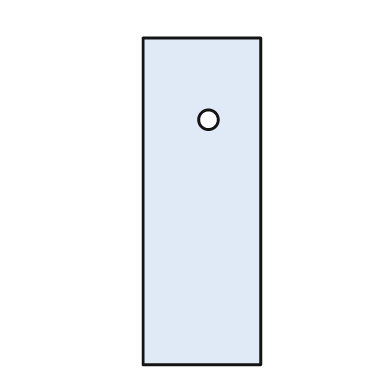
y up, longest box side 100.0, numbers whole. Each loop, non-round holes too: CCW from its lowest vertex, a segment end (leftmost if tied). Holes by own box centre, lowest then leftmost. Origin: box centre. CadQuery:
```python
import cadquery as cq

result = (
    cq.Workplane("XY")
    .moveTo(-18.0, -50.0)
    .lineTo(18.0, -50.0)
    .lineTo(18.0, 50.0)
    .lineTo(-18.0, 50.0)
    .close()
    .moveTo(2.0, 25.0)
    .circle(3.0)
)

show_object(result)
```